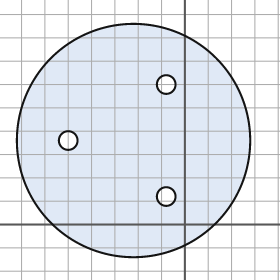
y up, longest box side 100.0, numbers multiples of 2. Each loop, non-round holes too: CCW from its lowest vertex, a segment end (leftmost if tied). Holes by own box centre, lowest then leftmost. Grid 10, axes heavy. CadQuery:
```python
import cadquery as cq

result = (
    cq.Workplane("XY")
    .moveTo(-22.0, 36.0)
    .circle(50.0)
    .moveTo(-8.0, 12.0)
    .circle(4.0)
    .moveTo(-50.0, 36.0)
    .circle(4.0)
    .moveTo(-8.0, 60.0)
    .circle(4.0)
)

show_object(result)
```